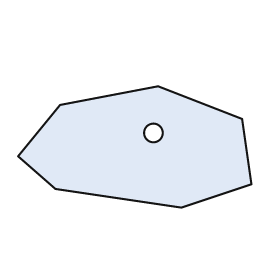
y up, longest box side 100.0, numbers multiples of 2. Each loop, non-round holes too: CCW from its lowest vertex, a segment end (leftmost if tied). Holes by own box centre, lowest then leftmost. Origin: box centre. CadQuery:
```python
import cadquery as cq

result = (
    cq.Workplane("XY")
    .moveTo(20.0, -26.0)
    .lineTo(50.0, -16.0)
    .lineTo(46.0, 12.0)
    .lineTo(10.0, 26.0)
    .lineTo(-32.0, 18.0)
    .lineTo(-50.0, -4.0)
    .lineTo(-34.0, -18.0)
    .close()
    .moveTo(8.0, 6.0)
    .circle(4.0)
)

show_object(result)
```